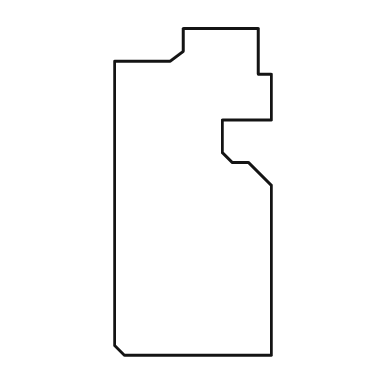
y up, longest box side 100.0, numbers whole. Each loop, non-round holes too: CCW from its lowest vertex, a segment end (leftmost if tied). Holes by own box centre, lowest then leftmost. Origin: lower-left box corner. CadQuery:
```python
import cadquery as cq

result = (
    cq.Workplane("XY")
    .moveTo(3.0, 0.0)
    .lineTo(48.0, 0.0)
    .lineTo(48.0, 52.0)
    .lineTo(41.0, 59.0)
    .lineTo(36.0, 59.0)
    .lineTo(33.0, 62.0)
    .lineTo(33.0, 72.0)
    .lineTo(48.0, 72.0)
    .lineTo(48.0, 86.0)
    .lineTo(44.0, 86.0)
    .lineTo(44.0, 100.0)
    .lineTo(21.0, 100.0)
    .lineTo(21.0, 93.0)
    .lineTo(17.0, 90.0)
    .lineTo(0.0, 90.0)
    .lineTo(0.0, 3.0)
    .close()
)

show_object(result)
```